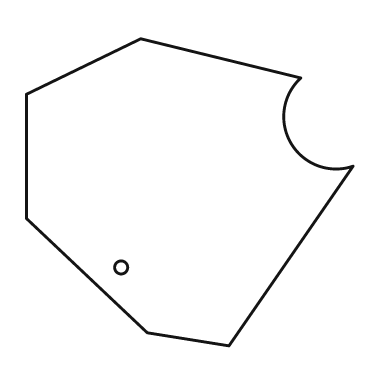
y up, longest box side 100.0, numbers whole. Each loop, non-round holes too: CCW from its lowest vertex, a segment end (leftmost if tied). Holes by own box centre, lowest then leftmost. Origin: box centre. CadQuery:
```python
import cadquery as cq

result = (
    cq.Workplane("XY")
    .moveTo(12.0, -47.0)
    .lineTo(50.0, 8.0)
    .threePointArc((31.0, 15.0), (34.0, 35.0))
    .lineTo(-15.0, 47.0)
    .lineTo(-50.0, 30.0)
    .lineTo(-50.0, -8.0)
    .lineTo(-13.0, -43.0)
    .close()
    .moveTo(-21.0, -23.0)
    .circle(2.0)
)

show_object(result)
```